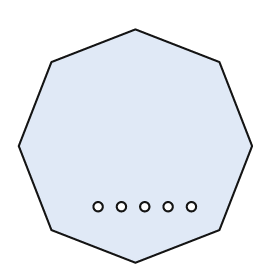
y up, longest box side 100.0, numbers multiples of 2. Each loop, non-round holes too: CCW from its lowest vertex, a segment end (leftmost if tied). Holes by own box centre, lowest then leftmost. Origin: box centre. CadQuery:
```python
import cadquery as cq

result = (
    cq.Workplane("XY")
    .moveTo(0.0, -50.0)
    .lineTo(36.0, -36.0)
    .lineTo(50.0, 0.0)
    .lineTo(36.0, 36.0)
    .lineTo(0.0, 50.0)
    .lineTo(-36.0, 36.0)
    .lineTo(-50.0, 0.0)
    .lineTo(-36.0, -36.0)
    .close()
    .moveTo(-16.0, -26.0)
    .circle(2.0)
    .moveTo(-6.0, -26.0)
    .circle(2.0)
    .moveTo(4.0, -26.0)
    .circle(2.0)
    .moveTo(14.0, -26.0)
    .circle(2.0)
    .moveTo(24.0, -26.0)
    .circle(2.0)
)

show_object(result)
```